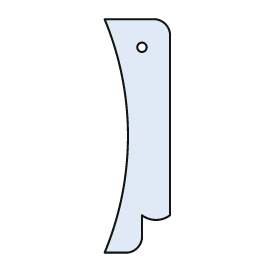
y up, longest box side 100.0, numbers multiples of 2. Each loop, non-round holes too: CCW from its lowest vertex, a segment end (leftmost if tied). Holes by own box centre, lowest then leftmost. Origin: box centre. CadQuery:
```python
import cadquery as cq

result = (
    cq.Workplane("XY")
    .moveTo(-14.0, -50.0)
    .lineTo(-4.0, -50.0)
    .threePointArc((0.0, -48.0), (2.0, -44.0))
    .lineTo(2.0, -34.0)
    .threePointArc((8.0, -36.0), (14.0, -34.0))
    .lineTo(14.0, 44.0)
    .threePointArc((12.0, 48.0), (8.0, 50.0))
    .lineTo(-14.0, 50.0)
    .threePointArc((-4.0, 0.0), (-14.0, -50.0))
    .close()
    .moveTo(2.0, 38.0)
    .circle(2.0)
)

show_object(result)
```